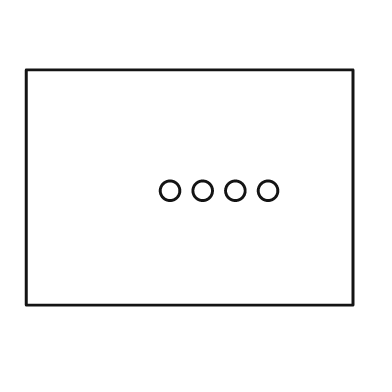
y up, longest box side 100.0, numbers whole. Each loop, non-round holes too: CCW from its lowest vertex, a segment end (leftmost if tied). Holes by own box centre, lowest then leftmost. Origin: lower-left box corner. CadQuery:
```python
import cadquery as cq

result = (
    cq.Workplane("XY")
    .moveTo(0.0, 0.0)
    .lineTo(100.0, 0.0)
    .lineTo(100.0, 72.0)
    .lineTo(0.0, 72.0)
    .close()
    .moveTo(44.0, 35.0)
    .circle(3.0)
    .moveTo(54.0, 35.0)
    .circle(3.0)
    .moveTo(64.0, 35.0)
    .circle(3.0)
    .moveTo(74.0, 35.0)
    .circle(3.0)
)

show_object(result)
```